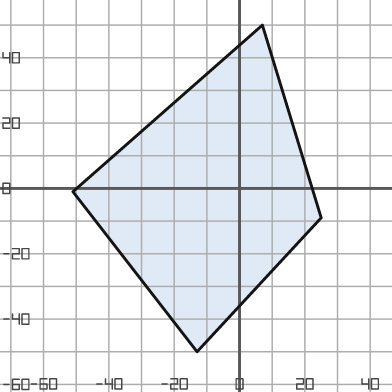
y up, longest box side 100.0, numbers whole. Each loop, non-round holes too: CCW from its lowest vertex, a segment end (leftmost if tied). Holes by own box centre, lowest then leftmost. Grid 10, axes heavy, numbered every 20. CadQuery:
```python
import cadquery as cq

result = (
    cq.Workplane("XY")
    .moveTo(-13.0, -50.0)
    .lineTo(25.0, -9.0)
    .lineTo(7.0, 50.0)
    .lineTo(-51.0, -1.0)
    .close()
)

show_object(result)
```